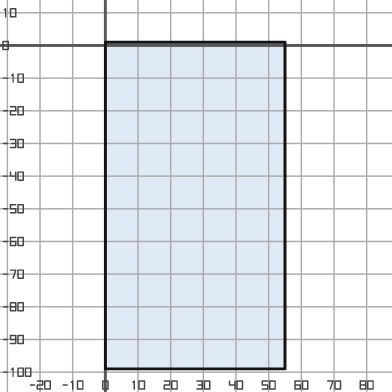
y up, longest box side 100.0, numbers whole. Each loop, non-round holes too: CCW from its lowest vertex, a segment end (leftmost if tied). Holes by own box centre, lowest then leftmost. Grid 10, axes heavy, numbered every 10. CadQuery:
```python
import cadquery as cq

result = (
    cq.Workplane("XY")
    .moveTo(0.0, -99.0)
    .lineTo(55.0, -99.0)
    .lineTo(55.0, 1.0)
    .lineTo(0.0, 1.0)
    .close()
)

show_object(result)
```